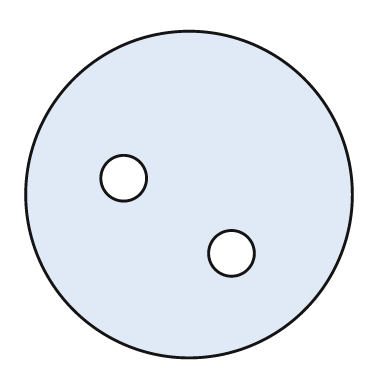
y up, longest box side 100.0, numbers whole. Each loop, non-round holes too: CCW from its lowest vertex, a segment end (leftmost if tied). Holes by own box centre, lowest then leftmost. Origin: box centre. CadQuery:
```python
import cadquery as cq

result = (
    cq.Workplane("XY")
    .moveTo(0.0, 0.0)
    .circle(50.0)
    .moveTo(13.0, -18.0)
    .circle(7.0)
    .moveTo(-20.0, 5.0)
    .circle(7.0)
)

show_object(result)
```